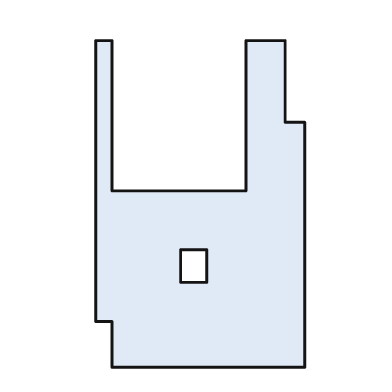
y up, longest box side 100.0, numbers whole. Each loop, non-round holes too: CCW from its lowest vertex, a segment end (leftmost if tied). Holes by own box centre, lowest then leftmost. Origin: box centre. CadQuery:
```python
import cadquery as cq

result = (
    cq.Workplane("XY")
    .moveTo(-27.0, -50.0)
    .lineTo(32.0, -50.0)
    .lineTo(32.0, 25.0)
    .lineTo(26.0, 25.0)
    .lineTo(26.0, 50.0)
    .lineTo(14.0, 50.0)
    .lineTo(14.0, 4.0)
    .lineTo(-27.0, 4.0)
    .lineTo(-27.0, 50.0)
    .lineTo(-32.0, 50.0)
    .lineTo(-32.0, -36.0)
    .lineTo(-27.0, -36.0)
    .close()
    .moveTo(-6.0, -24.0)
    .lineTo(2.0, -24.0)
    .lineTo(2.0, -14.0)
    .lineTo(-6.0, -14.0)
    .close()
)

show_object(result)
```